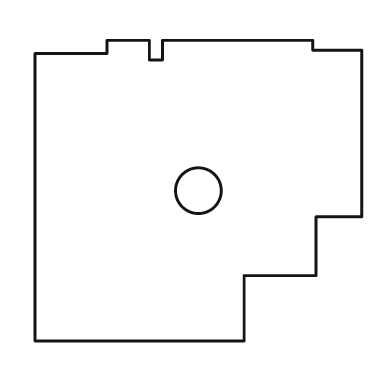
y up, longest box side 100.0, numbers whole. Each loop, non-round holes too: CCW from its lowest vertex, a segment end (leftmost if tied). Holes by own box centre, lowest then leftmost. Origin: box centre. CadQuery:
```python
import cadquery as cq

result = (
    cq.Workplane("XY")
    .moveTo(-50.0, -46.0)
    .lineTo(14.0, -46.0)
    .lineTo(14.0, -26.0)
    .lineTo(36.0, -26.0)
    .lineTo(36.0, -8.0)
    .lineTo(50.0, -8.0)
    .lineTo(50.0, 43.0)
    .lineTo(35.0, 43.0)
    .lineTo(35.0, 46.0)
    .lineTo(-11.0, 46.0)
    .lineTo(-11.0, 40.0)
    .lineTo(-15.0, 40.0)
    .lineTo(-15.0, 46.0)
    .lineTo(-28.0, 46.0)
    .lineTo(-28.0, 42.0)
    .lineTo(-50.0, 42.0)
    .close()
    .moveTo(0.0, 0.0)
    .circle(7.0)
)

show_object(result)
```